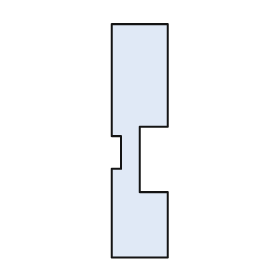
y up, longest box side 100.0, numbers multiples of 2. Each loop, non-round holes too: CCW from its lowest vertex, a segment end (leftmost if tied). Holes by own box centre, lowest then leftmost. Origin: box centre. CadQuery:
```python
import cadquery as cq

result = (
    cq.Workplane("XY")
    .moveTo(-12.0, -50.0)
    .lineTo(12.0, -50.0)
    .lineTo(12.0, -22.0)
    .lineTo(0.0, -22.0)
    .lineTo(0.0, 6.0)
    .lineTo(12.0, 6.0)
    .lineTo(12.0, 50.0)
    .lineTo(-12.0, 50.0)
    .lineTo(-12.0, 2.0)
    .lineTo(-8.0, 2.0)
    .lineTo(-8.0, -12.0)
    .lineTo(-12.0, -12.0)
    .close()
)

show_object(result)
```